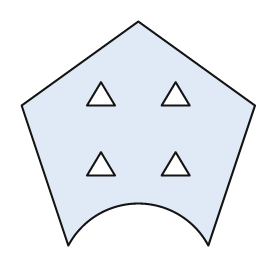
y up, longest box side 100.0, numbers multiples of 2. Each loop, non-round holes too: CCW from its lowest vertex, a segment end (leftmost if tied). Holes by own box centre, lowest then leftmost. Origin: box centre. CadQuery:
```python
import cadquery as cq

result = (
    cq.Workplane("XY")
    .moveTo(-30.0, -48.0)
    .threePointArc((0.0, -30.0), (30.0, -48.0))
    .lineTo(50.0, 12.0)
    .lineTo(0.0, 48.0)
    .lineTo(-50.0, 12.0)
    .close()
    .moveTo(-22.0, -18.0)
    .lineTo(-10.0, -18.0)
    .lineTo(-16.0, -8.0)
    .close()
    .moveTo(10.0, -18.0)
    .lineTo(22.0, -18.0)
    .lineTo(16.0, -8.0)
    .close()
    .moveTo(-22.0, 12.0)
    .lineTo(-10.0, 12.0)
    .lineTo(-16.0, 22.0)
    .close()
    .moveTo(10.0, 12.0)
    .lineTo(22.0, 12.0)
    .lineTo(16.0, 22.0)
    .close()
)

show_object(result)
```